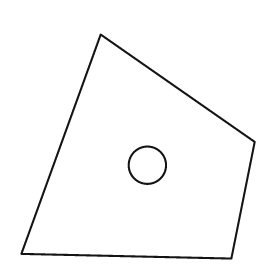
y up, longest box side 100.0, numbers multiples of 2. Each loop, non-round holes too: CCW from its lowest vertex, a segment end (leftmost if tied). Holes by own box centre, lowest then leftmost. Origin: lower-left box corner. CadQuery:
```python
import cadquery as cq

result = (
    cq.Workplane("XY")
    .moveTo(90.0, 0.0)
    .lineTo(100.0, 50.0)
    .lineTo(34.0, 96.0)
    .lineTo(0.0, 2.0)
    .close()
    .moveTo(54.0, 40.0)
    .circle(8.0)
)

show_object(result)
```